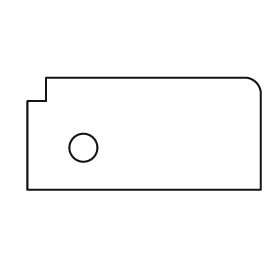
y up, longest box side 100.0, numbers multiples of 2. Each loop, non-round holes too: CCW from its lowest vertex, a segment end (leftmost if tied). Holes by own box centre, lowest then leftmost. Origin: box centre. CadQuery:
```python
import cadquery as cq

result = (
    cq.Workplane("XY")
    .moveTo(-50.0, -24.0)
    .lineTo(50.0, -24.0)
    .lineTo(50.0, 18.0)
    .threePointArc((48.0, 22.0), (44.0, 24.0))
    .lineTo(-42.0, 24.0)
    .lineTo(-42.0, 14.0)
    .lineTo(-50.0, 14.0)
    .close()
    .moveTo(-26.0, -6.0)
    .circle(6.0)
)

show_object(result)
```